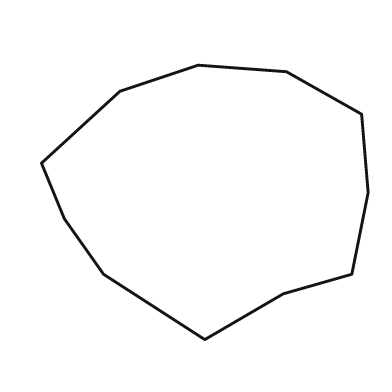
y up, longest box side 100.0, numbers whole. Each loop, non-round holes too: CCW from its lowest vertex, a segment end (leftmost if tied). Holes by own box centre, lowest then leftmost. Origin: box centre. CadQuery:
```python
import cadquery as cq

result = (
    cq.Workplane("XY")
    .moveTo(0.0, -42.0)
    .lineTo(24.0, -28.0)
    .lineTo(45.0, -22.0)
    .lineTo(50.0, 3.0)
    .lineTo(48.0, 27.0)
    .lineTo(25.0, 40.0)
    .lineTo(-2.0, 42.0)
    .lineTo(-26.0, 34.0)
    .lineTo(-50.0, 12.0)
    .lineTo(-43.0, -5.0)
    .lineTo(-31.0, -22.0)
    .close()
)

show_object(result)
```